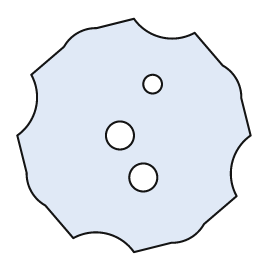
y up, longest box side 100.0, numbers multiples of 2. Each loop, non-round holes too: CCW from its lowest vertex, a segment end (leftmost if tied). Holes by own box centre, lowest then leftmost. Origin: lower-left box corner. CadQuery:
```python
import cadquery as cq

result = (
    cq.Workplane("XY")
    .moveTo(50.0, 0.0)
    .lineTo(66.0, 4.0)
    .threePointArc((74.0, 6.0), (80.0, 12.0))
    .lineTo(94.0, 24.0)
    .threePointArc((92.0, 38.0), (100.0, 50.0))
    .lineTo(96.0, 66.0)
    .threePointArc((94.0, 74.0), (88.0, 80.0))
    .lineTo(76.0, 94.0)
    .threePointArc((62.0, 92.0), (50.0, 100.0))
    .lineTo(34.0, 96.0)
    .threePointArc((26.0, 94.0), (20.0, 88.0))
    .lineTo(6.0, 76.0)
    .threePointArc((8.0, 62.0), (0.0, 50.0))
    .lineTo(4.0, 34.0)
    .threePointArc((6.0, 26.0), (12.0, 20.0))
    .lineTo(24.0, 6.0)
    .threePointArc((38.0, 8.0), (50.0, 0.0))
    .close()
    .moveTo(54.0, 32.0)
    .circle(6.0)
    .moveTo(44.0, 50.0)
    .circle(6.0)
    .moveTo(58.0, 72.0)
    .circle(4.0)
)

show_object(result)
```